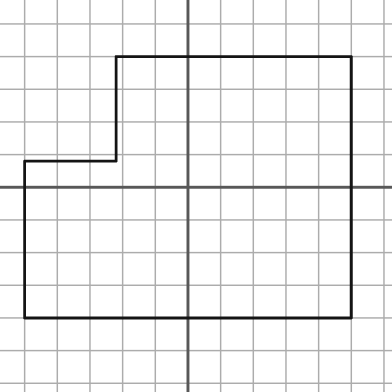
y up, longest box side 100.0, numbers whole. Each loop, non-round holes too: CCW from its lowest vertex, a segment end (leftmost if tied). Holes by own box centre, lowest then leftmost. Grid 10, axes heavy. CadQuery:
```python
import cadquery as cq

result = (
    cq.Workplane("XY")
    .moveTo(-50.0, -40.0)
    .lineTo(50.0, -40.0)
    .lineTo(50.0, 40.0)
    .lineTo(-22.0, 40.0)
    .lineTo(-22.0, 8.0)
    .lineTo(-50.0, 8.0)
    .close()
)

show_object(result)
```